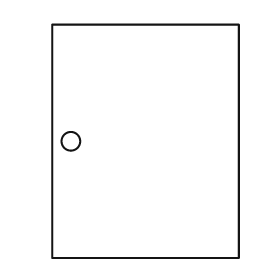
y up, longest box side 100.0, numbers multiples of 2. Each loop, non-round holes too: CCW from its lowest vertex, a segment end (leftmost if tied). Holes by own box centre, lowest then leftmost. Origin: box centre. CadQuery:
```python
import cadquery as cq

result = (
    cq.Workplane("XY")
    .moveTo(-40.0, -50.0)
    .lineTo(40.0, -50.0)
    .lineTo(40.0, 50.0)
    .lineTo(-40.0, 50.0)
    .close()
    .moveTo(-32.0, 0.0)
    .circle(4.0)
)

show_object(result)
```